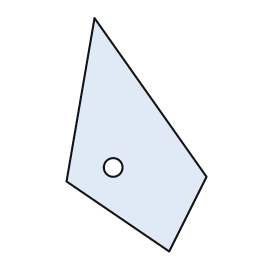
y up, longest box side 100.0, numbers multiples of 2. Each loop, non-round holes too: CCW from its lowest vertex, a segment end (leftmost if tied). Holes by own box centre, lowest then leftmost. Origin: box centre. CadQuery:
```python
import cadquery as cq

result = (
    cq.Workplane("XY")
    .moveTo(14.0, -50.0)
    .lineTo(30.0, -18.0)
    .lineTo(-18.0, 50.0)
    .lineTo(-30.0, -20.0)
    .close()
    .moveTo(-10.0, -14.0)
    .circle(4.0)
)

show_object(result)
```